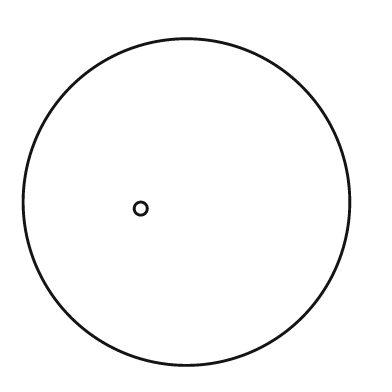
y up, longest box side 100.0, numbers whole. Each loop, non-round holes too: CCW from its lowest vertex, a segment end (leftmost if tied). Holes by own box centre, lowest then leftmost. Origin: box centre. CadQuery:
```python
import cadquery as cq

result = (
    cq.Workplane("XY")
    .moveTo(0.0, 0.0)
    .circle(50.0)
    .moveTo(-14.0, -2.0)
    .circle(2.0)
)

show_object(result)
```